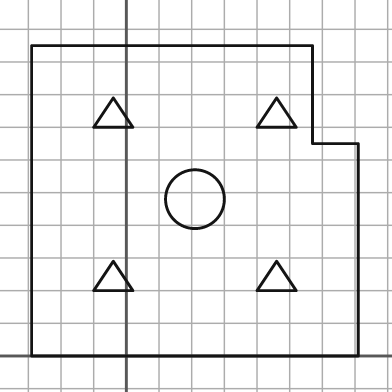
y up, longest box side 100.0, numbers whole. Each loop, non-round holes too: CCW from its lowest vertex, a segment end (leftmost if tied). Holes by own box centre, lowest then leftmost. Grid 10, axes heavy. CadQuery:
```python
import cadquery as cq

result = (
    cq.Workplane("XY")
    .moveTo(-29.0, 0.0)
    .lineTo(71.0, 0.0)
    .lineTo(71.0, 65.0)
    .lineTo(57.0, 65.0)
    .lineTo(57.0, 95.0)
    .lineTo(-29.0, 95.0)
    .close()
    .moveTo(-10.0, 20.0)
    .lineTo(2.0, 20.0)
    .lineTo(-4.0, 29.0)
    .close()
    .moveTo(40.0, 20.0)
    .lineTo(52.0, 20.0)
    .lineTo(46.0, 29.0)
    .close()
    .moveTo(21.0, 48.0)
    .circle(9.0)
    .moveTo(-10.0, 70.0)
    .lineTo(2.0, 70.0)
    .lineTo(-4.0, 79.0)
    .close()
    .moveTo(40.0, 70.0)
    .lineTo(52.0, 70.0)
    .lineTo(46.0, 79.0)
    .close()
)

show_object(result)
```